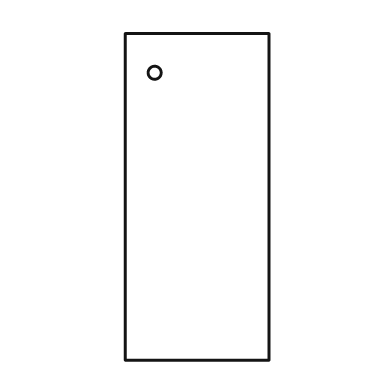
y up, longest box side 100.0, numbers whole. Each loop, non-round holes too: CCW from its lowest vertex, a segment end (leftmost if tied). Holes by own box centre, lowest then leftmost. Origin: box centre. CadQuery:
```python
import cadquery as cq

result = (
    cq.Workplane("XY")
    .moveTo(-22.0, -50.0)
    .lineTo(22.0, -50.0)
    .lineTo(22.0, 50.0)
    .lineTo(-22.0, 50.0)
    .close()
    .moveTo(-13.0, 38.0)
    .circle(2.0)
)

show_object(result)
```